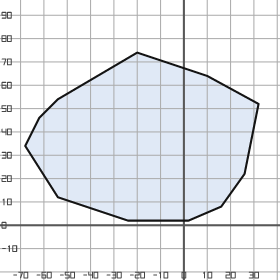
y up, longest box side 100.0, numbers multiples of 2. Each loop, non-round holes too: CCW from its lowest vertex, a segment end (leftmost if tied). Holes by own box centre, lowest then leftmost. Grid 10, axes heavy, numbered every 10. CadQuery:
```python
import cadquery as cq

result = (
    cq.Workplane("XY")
    .moveTo(-24.0, 2.0)
    .lineTo(2.0, 2.0)
    .lineTo(16.0, 8.0)
    .lineTo(26.0, 22.0)
    .lineTo(32.0, 52.0)
    .lineTo(10.0, 64.0)
    .lineTo(-20.0, 74.0)
    .lineTo(-54.0, 54.0)
    .lineTo(-62.0, 46.0)
    .lineTo(-68.0, 34.0)
    .lineTo(-54.0, 12.0)
    .close()
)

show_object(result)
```